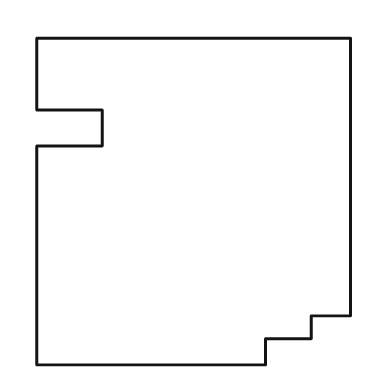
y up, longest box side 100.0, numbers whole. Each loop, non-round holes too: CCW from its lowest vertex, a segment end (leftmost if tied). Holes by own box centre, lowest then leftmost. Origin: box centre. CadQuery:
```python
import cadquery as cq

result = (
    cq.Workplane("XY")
    .moveTo(-48.0, -50.0)
    .lineTo(22.0, -50.0)
    .lineTo(22.0, -42.0)
    .lineTo(36.0, -42.0)
    .lineTo(36.0, -35.0)
    .lineTo(48.0, -35.0)
    .lineTo(48.0, 50.0)
    .lineTo(-48.0, 50.0)
    .lineTo(-48.0, 28.0)
    .lineTo(-28.0, 28.0)
    .lineTo(-28.0, 17.0)
    .lineTo(-48.0, 17.0)
    .close()
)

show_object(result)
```